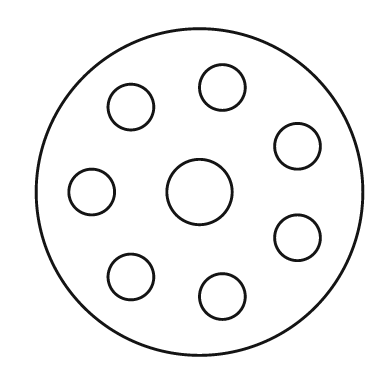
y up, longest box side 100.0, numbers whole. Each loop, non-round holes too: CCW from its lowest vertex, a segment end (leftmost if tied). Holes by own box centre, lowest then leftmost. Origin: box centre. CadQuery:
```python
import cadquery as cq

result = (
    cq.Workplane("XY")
    .moveTo(0.0, 0.0)
    .circle(50.0)
    .moveTo(7.0, -32.0)
    .circle(7.0)
    .moveTo(-21.0, -26.0)
    .circle(7.0)
    .moveTo(30.0, -14.0)
    .circle(7.0)
    .moveTo(-33.0, 0.0)
    .circle(7.0)
    .moveTo(0.0, 0.0)
    .circle(10.0)
    .moveTo(30.0, 14.0)
    .circle(7.0)
    .moveTo(-21.0, 26.0)
    .circle(7.0)
    .moveTo(7.0, 32.0)
    .circle(7.0)
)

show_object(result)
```